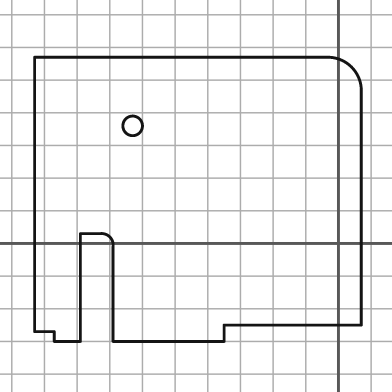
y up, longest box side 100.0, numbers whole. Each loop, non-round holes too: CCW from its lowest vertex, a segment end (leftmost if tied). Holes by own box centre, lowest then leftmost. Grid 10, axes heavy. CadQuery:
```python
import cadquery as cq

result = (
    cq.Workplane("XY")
    .moveTo(-87.0, -30.0)
    .lineTo(-79.0, -30.0)
    .lineTo(-79.0, 3.0)
    .lineTo(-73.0, 3.0)
    .threePointArc((-70.0, 2.0), (-69.0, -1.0))
    .lineTo(-69.0, -30.0)
    .lineTo(-35.0, -30.0)
    .lineTo(-35.0, -25.0)
    .lineTo(7.0, -25.0)
    .lineTo(7.0, 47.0)
    .threePointArc((4.0, 54.0), (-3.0, 57.0))
    .lineTo(-93.0, 57.0)
    .lineTo(-93.0, -27.0)
    .lineTo(-87.0, -27.0)
    .close()
    .moveTo(-63.0, 36.0)
    .circle(3.0)
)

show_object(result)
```